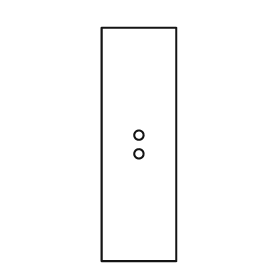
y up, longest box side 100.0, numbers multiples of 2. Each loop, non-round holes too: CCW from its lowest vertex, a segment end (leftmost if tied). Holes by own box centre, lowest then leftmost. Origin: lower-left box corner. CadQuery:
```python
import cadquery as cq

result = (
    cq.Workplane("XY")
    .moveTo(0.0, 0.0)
    .lineTo(32.0, 0.0)
    .lineTo(32.0, 100.0)
    .lineTo(0.0, 100.0)
    .close()
    .moveTo(16.0, 46.0)
    .circle(2.0)
    .moveTo(16.0, 54.0)
    .circle(2.0)
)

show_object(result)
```